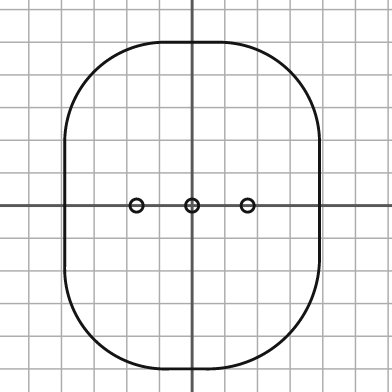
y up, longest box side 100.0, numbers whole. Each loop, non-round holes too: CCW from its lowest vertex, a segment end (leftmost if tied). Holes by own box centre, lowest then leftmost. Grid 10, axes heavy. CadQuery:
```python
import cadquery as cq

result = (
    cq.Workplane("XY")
    .moveTo(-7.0, -50.0)
    .lineTo(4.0, -50.0)
    .threePointArc((29.0, -40.0), (39.0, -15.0))
    .lineTo(39.0, 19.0)
    .threePointArc((30.0, 41.0), (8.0, 50.0))
    .lineTo(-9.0, 50.0)
    .threePointArc((-30.0, 41.0), (-39.0, 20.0))
    .lineTo(-39.0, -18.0)
    .threePointArc((-30.0, -41.0), (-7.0, -50.0))
    .close()
    .moveTo(-17.0, 0.0)
    .circle(2.0)
    .moveTo(0.0, 0.0)
    .circle(2.0)
    .moveTo(17.0, 0.0)
    .circle(2.0)
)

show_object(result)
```